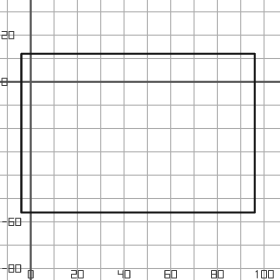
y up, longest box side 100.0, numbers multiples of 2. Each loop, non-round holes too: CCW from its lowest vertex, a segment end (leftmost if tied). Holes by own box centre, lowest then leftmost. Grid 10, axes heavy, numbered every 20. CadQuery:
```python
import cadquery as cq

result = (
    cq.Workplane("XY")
    .moveTo(-4.0, -56.0)
    .lineTo(96.0, -56.0)
    .lineTo(96.0, 12.0)
    .lineTo(-4.0, 12.0)
    .close()
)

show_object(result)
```